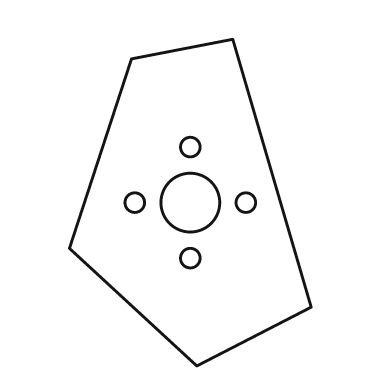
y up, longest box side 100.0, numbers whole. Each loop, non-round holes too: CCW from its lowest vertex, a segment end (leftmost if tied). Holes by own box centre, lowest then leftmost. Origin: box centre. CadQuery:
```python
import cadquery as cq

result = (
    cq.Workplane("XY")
    .moveTo(2.0, -50.0)
    .lineTo(37.0, -32.0)
    .lineTo(13.0, 50.0)
    .lineTo(-18.0, 44.0)
    .lineTo(-37.0, -14.0)
    .close()
    .moveTo(0.0, -17.0)
    .circle(3.0)
    .moveTo(-17.0, 0.0)
    .circle(3.0)
    .moveTo(0.0, 0.0)
    .circle(9.0)
    .moveTo(17.0, 0.0)
    .circle(3.0)
    .moveTo(0.0, 17.0)
    .circle(3.0)
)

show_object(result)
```